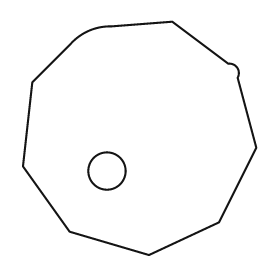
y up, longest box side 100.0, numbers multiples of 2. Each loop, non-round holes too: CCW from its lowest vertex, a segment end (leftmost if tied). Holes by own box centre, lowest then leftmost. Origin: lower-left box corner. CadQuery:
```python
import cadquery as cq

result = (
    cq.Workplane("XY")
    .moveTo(54.0, 0.0)
    .lineTo(84.0, 14.0)
    .lineTo(100.0, 46.0)
    .lineTo(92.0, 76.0)
    .threePointArc((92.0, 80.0), (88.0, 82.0))
    .lineTo(64.0, 100.0)
    .lineTo(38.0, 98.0)
    .threePointArc((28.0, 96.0), (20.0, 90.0))
    .lineTo(4.0, 74.0)
    .lineTo(0.0, 38.0)
    .lineTo(20.0, 10.0)
    .close()
    .moveTo(36.0, 36.0)
    .circle(8.0)
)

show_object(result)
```